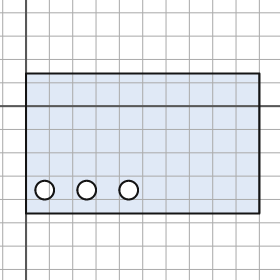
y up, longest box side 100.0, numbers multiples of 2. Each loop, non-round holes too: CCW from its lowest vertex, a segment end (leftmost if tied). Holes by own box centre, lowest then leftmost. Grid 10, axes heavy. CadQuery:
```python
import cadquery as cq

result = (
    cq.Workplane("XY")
    .moveTo(0.0, -46.0)
    .lineTo(100.0, -46.0)
    .lineTo(100.0, 14.0)
    .lineTo(0.0, 14.0)
    .close()
    .moveTo(8.0, -36.0)
    .circle(4.0)
    .moveTo(26.0, -36.0)
    .circle(4.0)
    .moveTo(44.0, -36.0)
    .circle(4.0)
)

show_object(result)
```